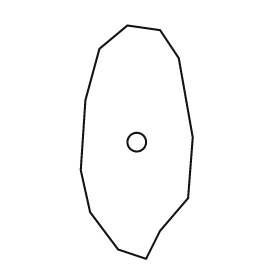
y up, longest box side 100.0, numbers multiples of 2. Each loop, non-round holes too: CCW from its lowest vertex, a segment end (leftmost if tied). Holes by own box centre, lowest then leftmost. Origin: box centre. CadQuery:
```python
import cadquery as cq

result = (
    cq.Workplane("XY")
    .moveTo(4.0, -50.0)
    .lineTo(10.0, -38.0)
    .lineTo(22.0, -24.0)
    .lineTo(24.0, 2.0)
    .lineTo(18.0, 36.0)
    .lineTo(10.0, 48.0)
    .lineTo(-4.0, 50.0)
    .lineTo(-16.0, 40.0)
    .lineTo(-22.0, 18.0)
    .lineTo(-24.0, -12.0)
    .lineTo(-20.0, -30.0)
    .lineTo(-8.0, -46.0)
    .close()
    .moveTo(0.0, 0.0)
    .circle(4.0)
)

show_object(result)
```